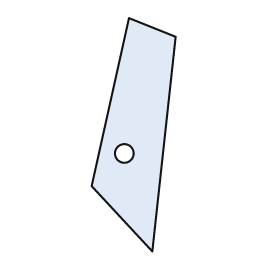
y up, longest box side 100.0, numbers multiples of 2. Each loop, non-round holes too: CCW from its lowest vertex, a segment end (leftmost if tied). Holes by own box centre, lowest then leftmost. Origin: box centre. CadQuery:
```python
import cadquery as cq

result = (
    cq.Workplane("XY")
    .moveTo(8.0, -50.0)
    .lineTo(18.0, 42.0)
    .lineTo(-2.0, 50.0)
    .lineTo(-18.0, -22.0)
    .close()
    .moveTo(-4.0, -8.0)
    .circle(4.0)
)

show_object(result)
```